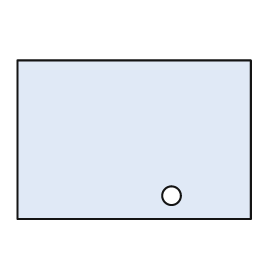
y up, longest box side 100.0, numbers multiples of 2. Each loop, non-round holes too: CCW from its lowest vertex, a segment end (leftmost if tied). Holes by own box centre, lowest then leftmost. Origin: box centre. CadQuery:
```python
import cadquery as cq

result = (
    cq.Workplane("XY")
    .moveTo(-50.0, -34.0)
    .lineTo(50.0, -34.0)
    .lineTo(50.0, 34.0)
    .lineTo(-50.0, 34.0)
    .close()
    .moveTo(16.0, -24.0)
    .circle(4.0)
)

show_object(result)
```